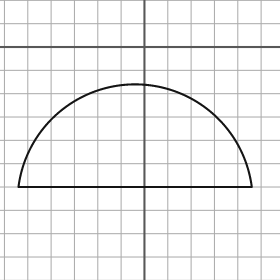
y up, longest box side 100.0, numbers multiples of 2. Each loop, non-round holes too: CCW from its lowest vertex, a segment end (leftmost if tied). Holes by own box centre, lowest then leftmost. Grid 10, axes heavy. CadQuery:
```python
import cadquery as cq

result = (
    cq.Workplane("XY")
    .moveTo(-54.0, -60.0)
    .lineTo(46.0, -60.0)
    .threePointArc((-4.0, -16.0), (-54.0, -60.0))
    .close()
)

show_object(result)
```